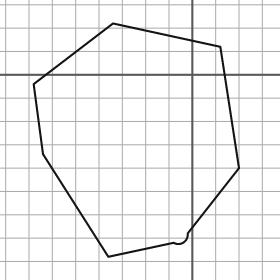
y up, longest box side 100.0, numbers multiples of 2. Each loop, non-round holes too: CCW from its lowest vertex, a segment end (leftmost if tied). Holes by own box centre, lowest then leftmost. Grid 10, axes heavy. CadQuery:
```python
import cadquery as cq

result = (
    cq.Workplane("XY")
    .moveTo(-36.0, -78.0)
    .lineTo(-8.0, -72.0)
    .threePointArc((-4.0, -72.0), (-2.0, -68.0))
    .lineTo(20.0, -40.0)
    .lineTo(12.0, 12.0)
    .lineTo(-34.0, 22.0)
    .lineTo(-68.0, -4.0)
    .lineTo(-64.0, -34.0)
    .close()
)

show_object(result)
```